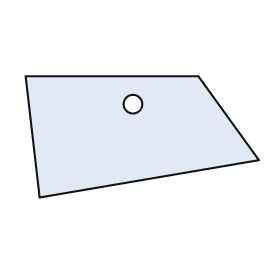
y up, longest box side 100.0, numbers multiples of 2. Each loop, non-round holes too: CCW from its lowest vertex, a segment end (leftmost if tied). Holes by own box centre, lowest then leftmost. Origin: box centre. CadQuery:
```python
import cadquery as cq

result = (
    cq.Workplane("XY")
    .moveTo(-44.0, -26.0)
    .lineTo(50.0, -10.0)
    .lineTo(24.0, 26.0)
    .lineTo(-50.0, 26.0)
    .close()
    .moveTo(-4.0, 14.0)
    .circle(4.0)
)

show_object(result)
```